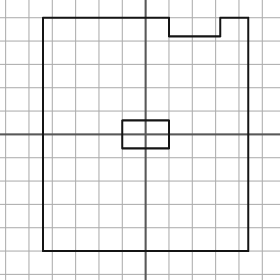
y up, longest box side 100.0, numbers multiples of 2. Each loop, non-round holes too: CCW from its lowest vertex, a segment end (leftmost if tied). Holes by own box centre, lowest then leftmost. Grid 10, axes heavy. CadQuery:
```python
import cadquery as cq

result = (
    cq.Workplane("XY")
    .moveTo(-44.0, -50.0)
    .lineTo(44.0, -50.0)
    .lineTo(44.0, 50.0)
    .lineTo(32.0, 50.0)
    .lineTo(32.0, 42.0)
    .lineTo(10.0, 42.0)
    .lineTo(10.0, 50.0)
    .lineTo(-44.0, 50.0)
    .close()
    .moveTo(-10.0, -6.0)
    .lineTo(10.0, -6.0)
    .lineTo(10.0, 6.0)
    .lineTo(-10.0, 6.0)
    .close()
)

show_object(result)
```